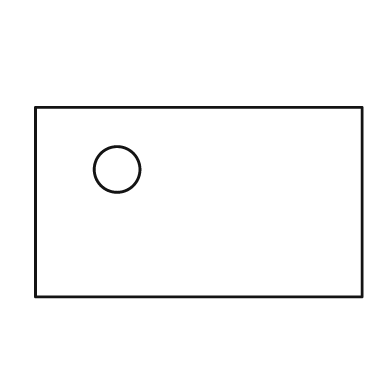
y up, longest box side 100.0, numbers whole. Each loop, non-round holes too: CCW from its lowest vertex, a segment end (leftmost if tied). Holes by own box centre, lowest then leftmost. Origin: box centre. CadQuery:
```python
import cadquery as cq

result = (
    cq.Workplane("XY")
    .moveTo(-50.0, -29.0)
    .lineTo(50.0, -29.0)
    .lineTo(50.0, 29.0)
    .lineTo(-50.0, 29.0)
    .close()
    .moveTo(-25.0, 10.0)
    .circle(7.0)
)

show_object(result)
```